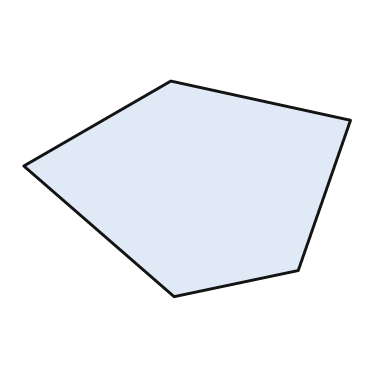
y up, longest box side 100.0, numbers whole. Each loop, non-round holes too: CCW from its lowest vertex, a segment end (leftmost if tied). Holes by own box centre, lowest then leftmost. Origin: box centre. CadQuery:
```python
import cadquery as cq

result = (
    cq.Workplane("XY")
    .moveTo(-4.0, -33.0)
    .lineTo(34.0, -25.0)
    .lineTo(50.0, 21.0)
    .lineTo(-5.0, 33.0)
    .lineTo(-50.0, 7.0)
    .close()
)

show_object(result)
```